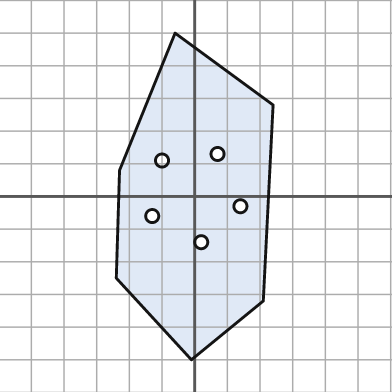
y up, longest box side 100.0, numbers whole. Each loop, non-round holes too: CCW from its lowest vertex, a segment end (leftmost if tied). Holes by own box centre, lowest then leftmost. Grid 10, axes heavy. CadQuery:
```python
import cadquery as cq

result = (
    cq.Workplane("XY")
    .moveTo(-1.0, -50.0)
    .lineTo(21.0, -32.0)
    .lineTo(24.0, 28.0)
    .lineTo(-6.0, 50.0)
    .lineTo(-23.0, 8.0)
    .lineTo(-24.0, -25.0)
    .close()
    .moveTo(2.0, -14.0)
    .circle(2.0)
    .moveTo(-13.0, -6.0)
    .circle(2.0)
    .moveTo(14.0, -3.0)
    .circle(2.0)
    .moveTo(-10.0, 11.0)
    .circle(2.0)
    .moveTo(7.0, 13.0)
    .circle(2.0)
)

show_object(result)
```